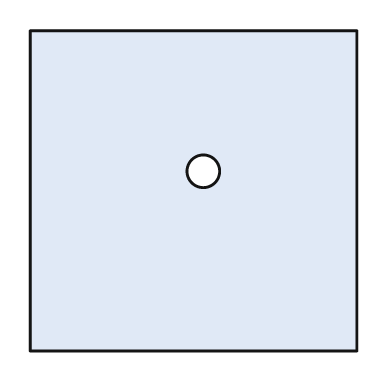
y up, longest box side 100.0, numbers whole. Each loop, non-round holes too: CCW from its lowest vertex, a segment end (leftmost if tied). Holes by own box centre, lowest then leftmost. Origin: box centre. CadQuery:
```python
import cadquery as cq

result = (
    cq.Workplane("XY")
    .moveTo(-50.0, -49.0)
    .lineTo(50.0, -49.0)
    .lineTo(50.0, 49.0)
    .lineTo(-50.0, 49.0)
    .close()
    .moveTo(3.0, 6.0)
    .circle(5.0)
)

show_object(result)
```